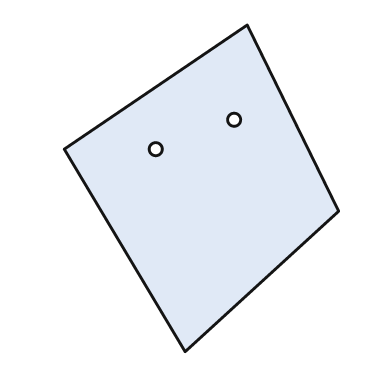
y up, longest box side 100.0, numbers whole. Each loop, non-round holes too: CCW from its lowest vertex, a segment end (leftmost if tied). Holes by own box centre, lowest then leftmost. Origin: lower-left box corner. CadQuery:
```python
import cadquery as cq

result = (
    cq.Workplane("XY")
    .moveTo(37.0, 0.0)
    .lineTo(84.0, 43.0)
    .lineTo(56.0, 100.0)
    .lineTo(0.0, 62.0)
    .close()
    .moveTo(28.0, 62.0)
    .circle(2.0)
    .moveTo(52.0, 71.0)
    .circle(2.0)
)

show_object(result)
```